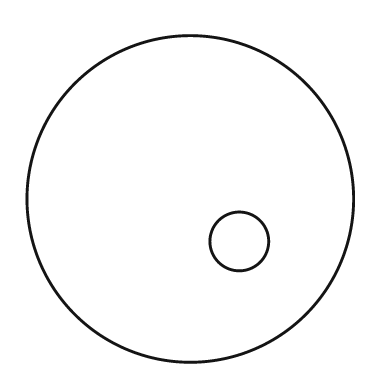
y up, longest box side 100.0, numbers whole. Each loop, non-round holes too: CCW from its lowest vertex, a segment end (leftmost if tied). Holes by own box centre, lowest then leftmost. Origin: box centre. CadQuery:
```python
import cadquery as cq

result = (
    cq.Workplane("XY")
    .moveTo(0.0, 0.0)
    .circle(50.0)
    .moveTo(15.0, -13.0)
    .circle(9.0)
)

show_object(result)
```